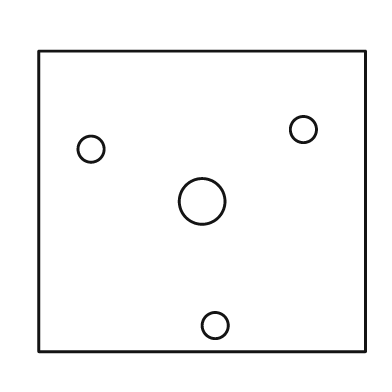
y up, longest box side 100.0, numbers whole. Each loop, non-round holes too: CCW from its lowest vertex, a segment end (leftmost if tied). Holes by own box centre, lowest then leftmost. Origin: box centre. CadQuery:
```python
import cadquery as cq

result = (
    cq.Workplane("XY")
    .moveTo(-50.0, -46.0)
    .lineTo(50.0, -46.0)
    .lineTo(50.0, 46.0)
    .lineTo(-50.0, 46.0)
    .close()
    .moveTo(4.0, -38.0)
    .circle(4.0)
    .moveTo(0.0, 0.0)
    .circle(7.0)
    .moveTo(-34.0, 16.0)
    .circle(4.0)
    .moveTo(31.0, 22.0)
    .circle(4.0)
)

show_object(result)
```